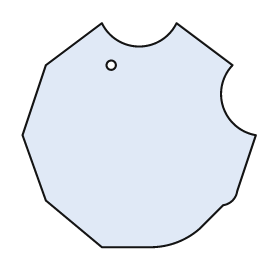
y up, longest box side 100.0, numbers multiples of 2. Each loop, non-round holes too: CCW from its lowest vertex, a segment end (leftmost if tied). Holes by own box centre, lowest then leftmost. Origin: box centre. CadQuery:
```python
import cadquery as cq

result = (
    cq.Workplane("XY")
    .moveTo(-16.0, -48.0)
    .lineTo(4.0, -48.0)
    .threePointArc((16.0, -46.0), (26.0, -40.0))
    .lineTo(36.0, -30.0)
    .threePointArc((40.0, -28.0), (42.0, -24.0))
    .lineTo(50.0, 0.0)
    .threePointArc((36.0, 12.0), (40.0, 30.0))
    .lineTo(16.0, 48.0)
    .threePointArc((0.0, 38.0), (-16.0, 48.0))
    .lineTo(-40.0, 30.0)
    .lineTo(-50.0, 0.0)
    .lineTo(-40.0, -28.0)
    .close()
    .moveTo(-12.0, 30.0)
    .circle(2.0)
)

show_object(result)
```